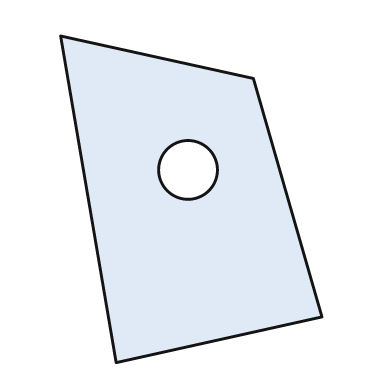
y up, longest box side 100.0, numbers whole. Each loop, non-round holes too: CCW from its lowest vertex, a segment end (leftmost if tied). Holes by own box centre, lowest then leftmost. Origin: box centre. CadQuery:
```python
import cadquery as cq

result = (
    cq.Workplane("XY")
    .moveTo(-23.0, -50.0)
    .lineTo(40.0, -36.0)
    .lineTo(19.0, 37.0)
    .lineTo(-40.0, 50.0)
    .close()
    .moveTo(-1.0, 9.0)
    .circle(9.0)
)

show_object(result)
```